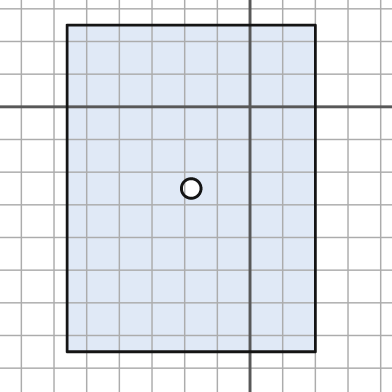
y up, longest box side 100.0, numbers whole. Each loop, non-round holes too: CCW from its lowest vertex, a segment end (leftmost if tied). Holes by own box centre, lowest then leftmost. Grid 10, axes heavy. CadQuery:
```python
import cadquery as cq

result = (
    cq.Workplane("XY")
    .moveTo(-56.0, -75.0)
    .lineTo(20.0, -75.0)
    .lineTo(20.0, 25.0)
    .lineTo(-56.0, 25.0)
    .close()
    .moveTo(-18.0, -25.0)
    .circle(3.0)
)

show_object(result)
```